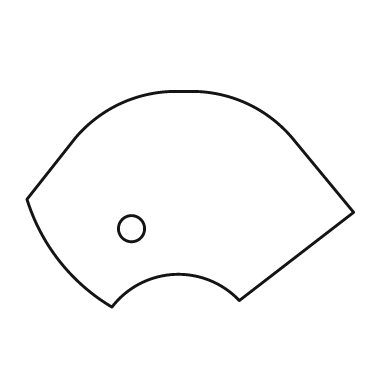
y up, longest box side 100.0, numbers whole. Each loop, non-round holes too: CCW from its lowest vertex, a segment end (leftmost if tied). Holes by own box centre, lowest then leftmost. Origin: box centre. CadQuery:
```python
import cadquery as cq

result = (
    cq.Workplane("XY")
    .moveTo(-24.0, -33.0)
    .threePointArc((-5.0, -23.0), (15.0, -31.0))
    .lineTo(50.0, -4.0)
    .lineTo(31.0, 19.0)
    .threePointArc((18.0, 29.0), (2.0, 33.0))
    .lineTo(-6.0, 33.0)
    .threePointArc((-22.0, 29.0), (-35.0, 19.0))
    .lineTo(-50.0, 0.0)
    .threePointArc((-40.0, -19.0), (-24.0, -33.0))
    .close()
    .moveTo(-18.0, -9.0)
    .circle(4.0)
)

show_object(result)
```